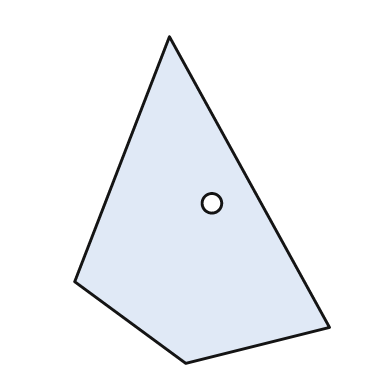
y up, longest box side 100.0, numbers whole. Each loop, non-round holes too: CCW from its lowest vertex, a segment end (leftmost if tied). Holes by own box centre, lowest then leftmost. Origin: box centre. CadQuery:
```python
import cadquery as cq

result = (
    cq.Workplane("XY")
    .moveTo(-5.0, -50.0)
    .lineTo(39.0, -39.0)
    .lineTo(-10.0, 50.0)
    .lineTo(-39.0, -25.0)
    .close()
    .moveTo(3.0, -1.0)
    .circle(3.0)
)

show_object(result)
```